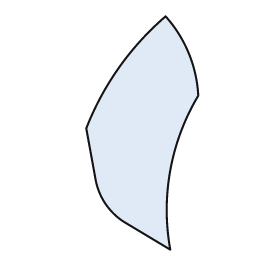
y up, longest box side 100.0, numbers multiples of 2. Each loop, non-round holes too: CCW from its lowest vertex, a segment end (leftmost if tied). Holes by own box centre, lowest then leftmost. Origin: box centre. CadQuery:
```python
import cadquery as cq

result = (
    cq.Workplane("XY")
    .moveTo(12.0, -50.0)
    .threePointArc((12.0, -16.0), (24.0, 16.0))
    .threePointArc((20.0, 34.0), (10.0, 50.0))
    .threePointArc((-10.0, 28.0), (-24.0, 2.0))
    .lineTo(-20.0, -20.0)
    .threePointArc((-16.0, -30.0), (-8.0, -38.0))
    .close()
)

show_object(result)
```